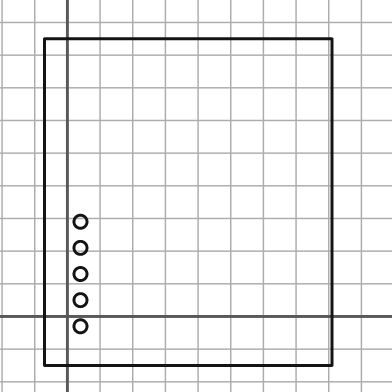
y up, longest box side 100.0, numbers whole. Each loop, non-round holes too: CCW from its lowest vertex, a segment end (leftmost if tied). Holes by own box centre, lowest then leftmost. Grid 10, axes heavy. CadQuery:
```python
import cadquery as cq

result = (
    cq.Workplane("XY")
    .moveTo(-7.0, -15.0)
    .lineTo(81.0, -15.0)
    .lineTo(81.0, 85.0)
    .lineTo(-7.0, 85.0)
    .close()
    .moveTo(4.0, -3.0)
    .circle(2.0)
    .moveTo(4.0, 5.0)
    .circle(2.0)
    .moveTo(4.0, 13.0)
    .circle(2.0)
    .moveTo(4.0, 21.0)
    .circle(2.0)
    .moveTo(4.0, 29.0)
    .circle(2.0)
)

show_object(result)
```